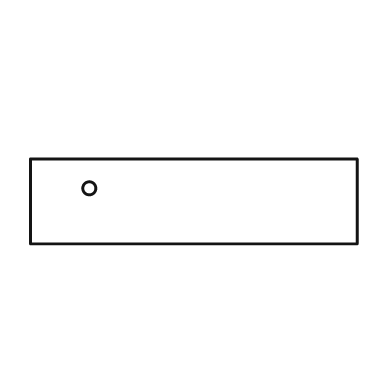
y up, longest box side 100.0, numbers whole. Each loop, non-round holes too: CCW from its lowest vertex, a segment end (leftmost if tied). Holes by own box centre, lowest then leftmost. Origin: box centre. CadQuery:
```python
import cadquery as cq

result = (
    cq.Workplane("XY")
    .moveTo(-50.0, -13.0)
    .lineTo(50.0, -13.0)
    .lineTo(50.0, 13.0)
    .lineTo(-50.0, 13.0)
    .close()
    .moveTo(-32.0, 4.0)
    .circle(2.0)
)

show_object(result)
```